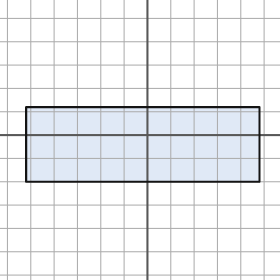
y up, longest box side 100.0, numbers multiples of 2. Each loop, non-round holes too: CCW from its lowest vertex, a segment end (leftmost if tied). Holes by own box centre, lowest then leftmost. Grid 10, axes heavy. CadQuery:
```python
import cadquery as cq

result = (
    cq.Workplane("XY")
    .moveTo(-52.0, -20.0)
    .lineTo(48.0, -20.0)
    .lineTo(48.0, 12.0)
    .lineTo(-52.0, 12.0)
    .close()
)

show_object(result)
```